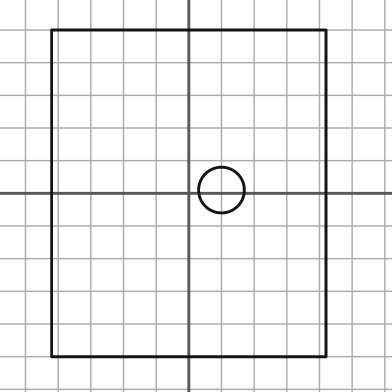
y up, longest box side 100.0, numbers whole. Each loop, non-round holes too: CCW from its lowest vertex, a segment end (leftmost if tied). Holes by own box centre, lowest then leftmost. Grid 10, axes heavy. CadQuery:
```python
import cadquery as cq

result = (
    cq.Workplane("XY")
    .moveTo(-42.0, -50.0)
    .lineTo(42.0, -50.0)
    .lineTo(42.0, 50.0)
    .lineTo(-42.0, 50.0)
    .close()
    .moveTo(10.0, 1.0)
    .circle(7.0)
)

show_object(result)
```